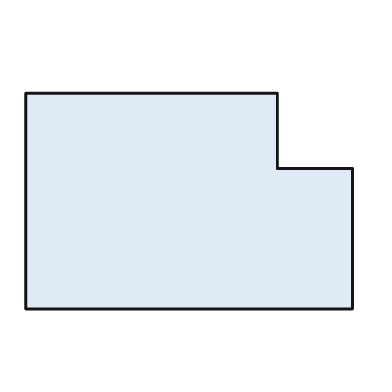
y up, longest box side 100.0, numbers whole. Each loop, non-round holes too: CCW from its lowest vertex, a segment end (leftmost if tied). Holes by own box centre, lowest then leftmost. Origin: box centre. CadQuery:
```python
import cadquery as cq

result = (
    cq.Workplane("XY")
    .moveTo(-50.0, -33.0)
    .lineTo(50.0, -33.0)
    .lineTo(50.0, 10.0)
    .lineTo(27.0, 10.0)
    .lineTo(27.0, 33.0)
    .lineTo(-50.0, 33.0)
    .close()
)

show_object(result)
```